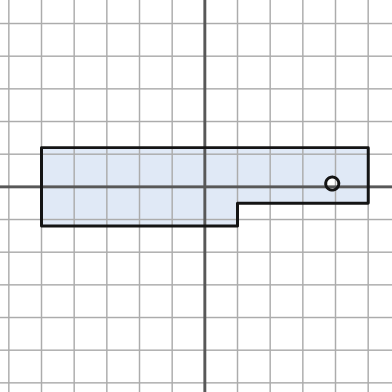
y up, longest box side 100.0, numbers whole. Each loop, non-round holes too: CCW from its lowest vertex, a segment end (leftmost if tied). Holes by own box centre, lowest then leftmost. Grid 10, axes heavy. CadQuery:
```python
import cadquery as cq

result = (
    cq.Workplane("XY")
    .moveTo(-50.0, -12.0)
    .lineTo(10.0, -12.0)
    .lineTo(10.0, -5.0)
    .lineTo(50.0, -5.0)
    .lineTo(50.0, 12.0)
    .lineTo(-50.0, 12.0)
    .close()
    .moveTo(39.0, 1.0)
    .circle(2.0)
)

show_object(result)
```